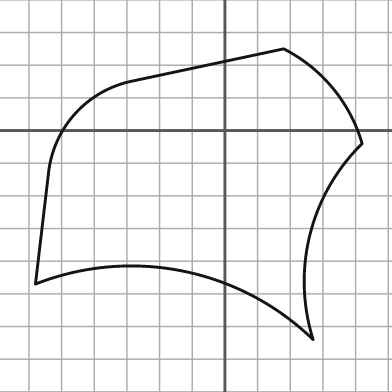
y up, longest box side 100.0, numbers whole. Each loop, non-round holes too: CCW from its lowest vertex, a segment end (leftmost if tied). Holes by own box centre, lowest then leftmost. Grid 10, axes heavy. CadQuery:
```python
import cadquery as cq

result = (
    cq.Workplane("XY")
    .moveTo(27.0, -64.0)
    .threePointArc((26.0, -32.0), (42.0, -4.0))
    .threePointArc((33.0, 13.0), (18.0, 25.0))
    .lineTo(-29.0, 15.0)
    .threePointArc((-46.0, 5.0), (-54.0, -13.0))
    .lineTo(-58.0, -47.0)
    .threePointArc((-13.0, -43.0), (27.0, -64.0))
    .close()
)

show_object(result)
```